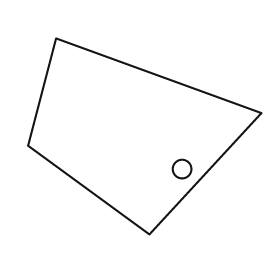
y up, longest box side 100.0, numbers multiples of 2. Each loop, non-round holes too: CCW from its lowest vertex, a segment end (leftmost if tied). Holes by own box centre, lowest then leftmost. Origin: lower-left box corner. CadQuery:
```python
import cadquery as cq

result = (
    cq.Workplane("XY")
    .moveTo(52.0, 0.0)
    .lineTo(100.0, 52.0)
    .lineTo(12.0, 84.0)
    .lineTo(0.0, 38.0)
    .close()
    .moveTo(66.0, 28.0)
    .circle(4.0)
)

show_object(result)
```